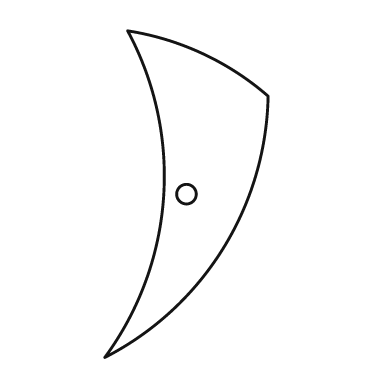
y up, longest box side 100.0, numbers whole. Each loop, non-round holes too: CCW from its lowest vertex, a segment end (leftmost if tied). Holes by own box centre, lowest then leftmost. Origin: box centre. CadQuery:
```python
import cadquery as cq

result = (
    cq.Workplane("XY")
    .moveTo(-25.0, -50.0)
    .threePointArc((11.0, -17.0), (25.0, 30.0))
    .threePointArc((5.0, 43.0), (-18.0, 50.0))
    .threePointArc((-7.0, -1.0), (-25.0, -50.0))
    .close()
    .moveTo(0.0, 0.0)
    .circle(3.0)
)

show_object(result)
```